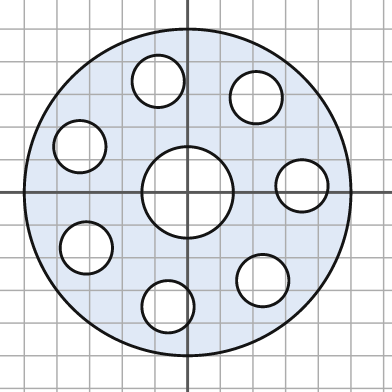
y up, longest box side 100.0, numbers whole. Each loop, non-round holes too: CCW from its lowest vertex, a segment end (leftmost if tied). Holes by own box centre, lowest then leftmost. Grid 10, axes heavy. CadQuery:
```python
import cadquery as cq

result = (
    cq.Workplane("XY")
    .moveTo(0.0, 0.0)
    .circle(50.0)
    .moveTo(-6.0, -35.0)
    .circle(8.0)
    .moveTo(23.0, -27.0)
    .circle(8.0)
    .moveTo(-31.0, -17.0)
    .circle(8.0)
    .moveTo(0.0, 0.0)
    .circle(14.0)
    .moveTo(35.0, 2.0)
    .circle(8.0)
    .moveTo(-33.0, 14.0)
    .circle(8.0)
    .moveTo(21.0, 29.0)
    .circle(8.0)
    .moveTo(-9.0, 34.0)
    .circle(8.0)
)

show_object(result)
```